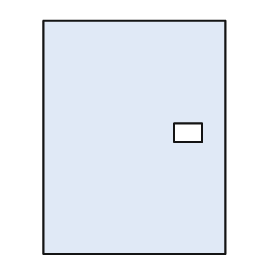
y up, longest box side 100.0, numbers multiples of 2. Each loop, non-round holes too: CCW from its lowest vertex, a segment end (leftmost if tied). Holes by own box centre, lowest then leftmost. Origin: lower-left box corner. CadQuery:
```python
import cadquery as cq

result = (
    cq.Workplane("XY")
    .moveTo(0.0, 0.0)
    .lineTo(78.0, 0.0)
    .lineTo(78.0, 100.0)
    .lineTo(0.0, 100.0)
    .close()
    .moveTo(56.0, 48.0)
    .lineTo(68.0, 48.0)
    .lineTo(68.0, 56.0)
    .lineTo(56.0, 56.0)
    .close()
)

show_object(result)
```